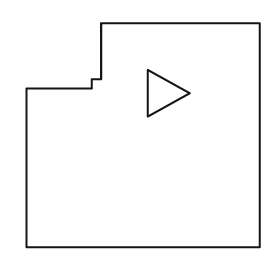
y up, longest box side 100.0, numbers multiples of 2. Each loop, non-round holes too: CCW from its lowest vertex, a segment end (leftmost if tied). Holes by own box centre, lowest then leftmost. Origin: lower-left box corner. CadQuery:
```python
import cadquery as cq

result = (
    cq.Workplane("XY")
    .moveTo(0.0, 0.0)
    .lineTo(100.0, 0.0)
    .lineTo(100.0, 96.0)
    .lineTo(32.0, 96.0)
    .lineTo(32.0, 72.0)
    .lineTo(28.0, 72.0)
    .lineTo(28.0, 68.0)
    .lineTo(0.0, 68.0)
    .close()
    .moveTo(52.0, 56.0)
    .lineTo(70.0, 66.0)
    .lineTo(52.0, 76.0)
    .close()
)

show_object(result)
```